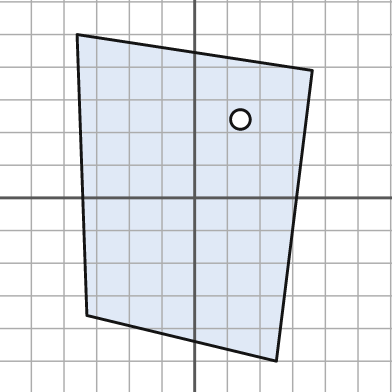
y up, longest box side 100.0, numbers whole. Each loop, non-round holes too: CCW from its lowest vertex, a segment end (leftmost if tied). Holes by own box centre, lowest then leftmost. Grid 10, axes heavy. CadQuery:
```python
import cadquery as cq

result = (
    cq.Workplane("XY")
    .moveTo(25.0, -50.0)
    .lineTo(36.0, 39.0)
    .lineTo(-36.0, 50.0)
    .lineTo(-33.0, -36.0)
    .close()
    .moveTo(14.0, 24.0)
    .circle(3.0)
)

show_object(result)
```